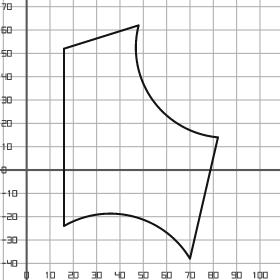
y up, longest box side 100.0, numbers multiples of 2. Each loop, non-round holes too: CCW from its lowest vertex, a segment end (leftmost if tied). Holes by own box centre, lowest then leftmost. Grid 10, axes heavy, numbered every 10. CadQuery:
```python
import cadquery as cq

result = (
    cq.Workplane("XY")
    .moveTo(70.0, -38.0)
    .lineTo(82.0, 14.0)
    .threePointArc((54.0, 30.0), (48.0, 62.0))
    .lineTo(16.0, 52.0)
    .lineTo(16.0, -24.0)
    .threePointArc((46.0, -20.0), (70.0, -38.0))
    .close()
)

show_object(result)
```